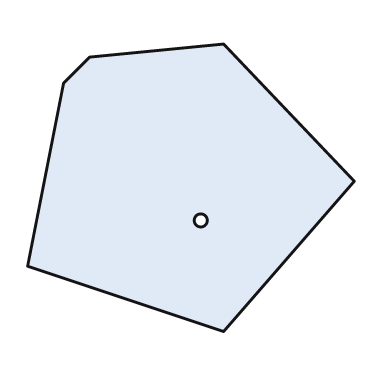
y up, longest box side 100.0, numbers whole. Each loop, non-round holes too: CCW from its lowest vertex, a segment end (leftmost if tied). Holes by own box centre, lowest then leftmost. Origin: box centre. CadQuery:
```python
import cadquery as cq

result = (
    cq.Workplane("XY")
    .moveTo(10.0, -44.0)
    .lineTo(50.0, 2.0)
    .lineTo(10.0, 44.0)
    .lineTo(-31.0, 40.0)
    .lineTo(-39.0, 32.0)
    .lineTo(-50.0, -24.0)
    .close()
    .moveTo(3.0, -10.0)
    .circle(2.0)
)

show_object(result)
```